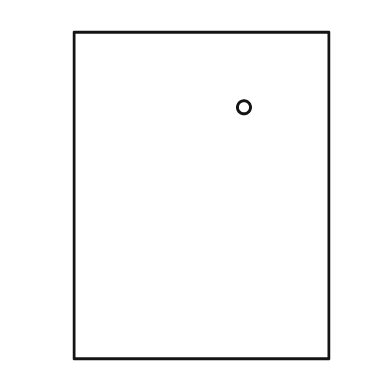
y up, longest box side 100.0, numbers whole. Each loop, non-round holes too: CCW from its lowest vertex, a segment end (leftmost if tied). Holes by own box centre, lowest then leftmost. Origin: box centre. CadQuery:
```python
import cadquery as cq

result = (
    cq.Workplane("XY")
    .moveTo(-39.0, -50.0)
    .lineTo(39.0, -50.0)
    .lineTo(39.0, 50.0)
    .lineTo(-39.0, 50.0)
    .close()
    .moveTo(13.0, 27.0)
    .circle(2.0)
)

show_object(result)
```